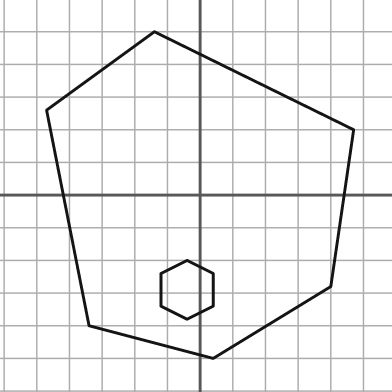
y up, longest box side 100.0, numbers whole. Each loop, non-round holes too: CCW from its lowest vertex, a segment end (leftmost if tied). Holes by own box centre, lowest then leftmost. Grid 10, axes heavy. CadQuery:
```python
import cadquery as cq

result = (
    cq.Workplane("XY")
    .moveTo(4.0, -50.0)
    .lineTo(40.0, -28.0)
    .lineTo(47.0, 20.0)
    .lineTo(-14.0, 50.0)
    .lineTo(-47.0, 26.0)
    .lineTo(-34.0, -40.0)
    .close()
    .moveTo(-4.0, -38.0)
    .lineTo(4.0, -34.0)
    .lineTo(4.0, -24.0)
    .lineTo(-4.0, -20.0)
    .lineTo(-12.0, -24.0)
    .lineTo(-12.0, -34.0)
    .close()
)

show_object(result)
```